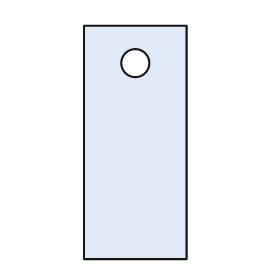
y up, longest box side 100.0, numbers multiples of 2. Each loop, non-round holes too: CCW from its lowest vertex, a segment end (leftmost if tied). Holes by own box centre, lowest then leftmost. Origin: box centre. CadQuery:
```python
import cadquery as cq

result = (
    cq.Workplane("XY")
    .moveTo(-22.0, -50.0)
    .lineTo(22.0, -50.0)
    .lineTo(22.0, 50.0)
    .lineTo(-22.0, 50.0)
    .close()
    .moveTo(0.0, 34.0)
    .circle(6.0)
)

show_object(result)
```